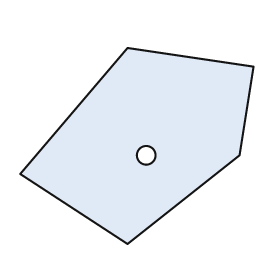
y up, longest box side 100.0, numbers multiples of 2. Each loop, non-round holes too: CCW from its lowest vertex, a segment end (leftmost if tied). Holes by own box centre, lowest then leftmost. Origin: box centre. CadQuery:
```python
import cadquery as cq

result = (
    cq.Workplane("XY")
    .moveTo(-4.0, -42.0)
    .lineTo(44.0, -4.0)
    .lineTo(50.0, 34.0)
    .lineTo(-4.0, 42.0)
    .lineTo(-50.0, -12.0)
    .close()
    .moveTo(4.0, -4.0)
    .circle(4.0)
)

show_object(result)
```